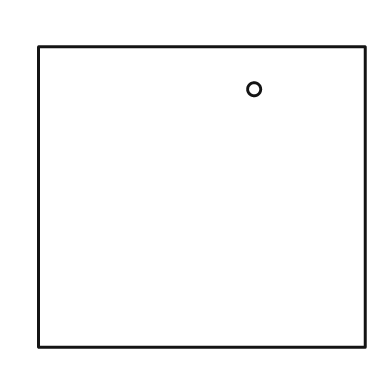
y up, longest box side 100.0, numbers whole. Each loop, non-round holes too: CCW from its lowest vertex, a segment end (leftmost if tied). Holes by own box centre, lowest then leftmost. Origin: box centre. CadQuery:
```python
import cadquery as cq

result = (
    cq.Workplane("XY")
    .moveTo(-50.0, -46.0)
    .lineTo(50.0, -46.0)
    .lineTo(50.0, 46.0)
    .lineTo(-50.0, 46.0)
    .close()
    .moveTo(16.0, 33.0)
    .circle(2.0)
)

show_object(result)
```